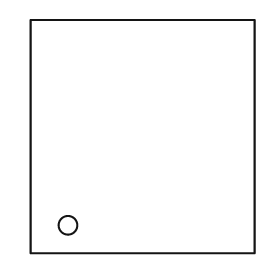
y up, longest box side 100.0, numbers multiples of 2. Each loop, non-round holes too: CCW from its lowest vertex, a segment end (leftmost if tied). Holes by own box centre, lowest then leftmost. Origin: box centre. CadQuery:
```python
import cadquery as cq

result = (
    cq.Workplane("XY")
    .moveTo(-48.0, -50.0)
    .lineTo(48.0, -50.0)
    .lineTo(48.0, 50.0)
    .lineTo(-48.0, 50.0)
    .close()
    .moveTo(-32.0, -38.0)
    .circle(4.0)
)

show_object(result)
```